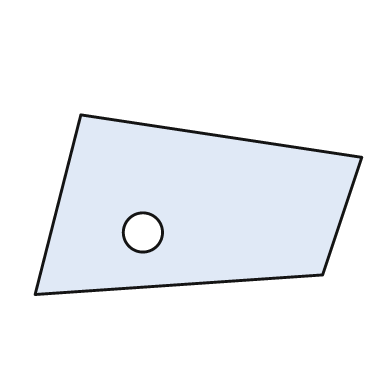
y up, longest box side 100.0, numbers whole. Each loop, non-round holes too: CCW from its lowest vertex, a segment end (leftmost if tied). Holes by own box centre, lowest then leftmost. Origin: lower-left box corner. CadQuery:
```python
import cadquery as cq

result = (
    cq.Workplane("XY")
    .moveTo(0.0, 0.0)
    .lineTo(88.0, 6.0)
    .lineTo(100.0, 42.0)
    .lineTo(14.0, 55.0)
    .close()
    .moveTo(33.0, 19.0)
    .circle(6.0)
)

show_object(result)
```